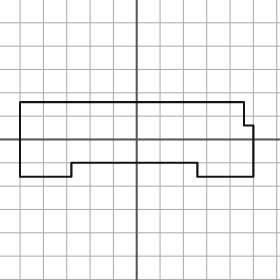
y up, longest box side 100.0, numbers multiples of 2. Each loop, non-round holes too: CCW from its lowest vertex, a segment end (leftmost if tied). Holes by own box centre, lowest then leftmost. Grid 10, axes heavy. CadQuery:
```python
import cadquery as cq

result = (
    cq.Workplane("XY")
    .moveTo(-50.0, -16.0)
    .lineTo(-28.0, -16.0)
    .lineTo(-28.0, -10.0)
    .lineTo(26.0, -10.0)
    .lineTo(26.0, -16.0)
    .lineTo(50.0, -16.0)
    .lineTo(50.0, 6.0)
    .lineTo(46.0, 6.0)
    .lineTo(46.0, 16.0)
    .lineTo(-50.0, 16.0)
    .close()
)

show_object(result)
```